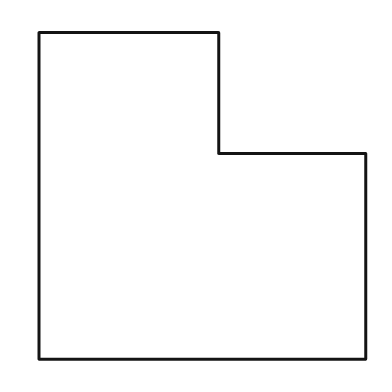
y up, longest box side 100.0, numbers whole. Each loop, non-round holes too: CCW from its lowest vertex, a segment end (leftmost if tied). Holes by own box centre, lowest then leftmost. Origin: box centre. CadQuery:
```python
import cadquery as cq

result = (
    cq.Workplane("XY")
    .moveTo(-50.0, -50.0)
    .lineTo(50.0, -50.0)
    .lineTo(50.0, 13.0)
    .lineTo(5.0, 13.0)
    .lineTo(5.0, 50.0)
    .lineTo(-50.0, 50.0)
    .close()
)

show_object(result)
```